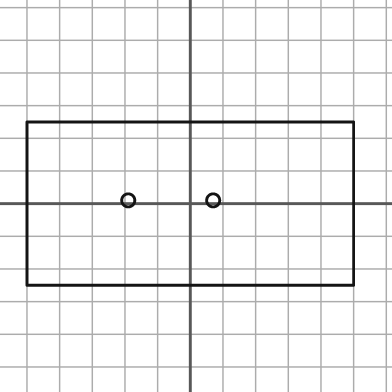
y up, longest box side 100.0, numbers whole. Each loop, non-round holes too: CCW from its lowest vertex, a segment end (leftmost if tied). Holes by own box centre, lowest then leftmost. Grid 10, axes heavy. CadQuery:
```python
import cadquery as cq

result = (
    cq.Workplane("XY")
    .moveTo(-50.0, -25.0)
    .lineTo(50.0, -25.0)
    .lineTo(50.0, 25.0)
    .lineTo(-50.0, 25.0)
    .close()
    .moveTo(-19.0, 1.0)
    .circle(2.0)
    .moveTo(7.0, 1.0)
    .circle(2.0)
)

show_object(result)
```